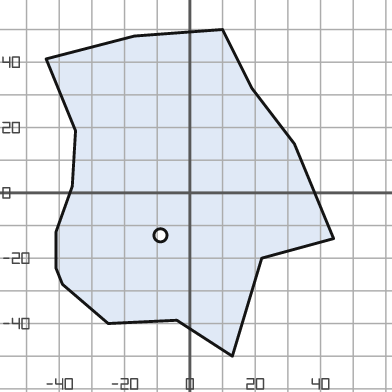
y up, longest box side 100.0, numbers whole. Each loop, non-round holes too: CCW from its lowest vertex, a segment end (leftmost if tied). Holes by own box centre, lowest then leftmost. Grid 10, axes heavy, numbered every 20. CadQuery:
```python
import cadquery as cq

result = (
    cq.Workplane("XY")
    .moveTo(13.0, -50.0)
    .lineTo(22.0, -20.0)
    .lineTo(44.0, -14.0)
    .lineTo(32.0, 15.0)
    .lineTo(19.0, 32.0)
    .lineTo(10.0, 50.0)
    .lineTo(-17.0, 48.0)
    .lineTo(-44.0, 41.0)
    .lineTo(-35.0, 19.0)
    .lineTo(-36.0, 2.0)
    .lineTo(-41.0, -12.0)
    .lineTo(-41.0, -23.0)
    .lineTo(-39.0, -28.0)
    .lineTo(-25.0, -40.0)
    .lineTo(-4.0, -39.0)
    .close()
    .moveTo(-9.0, -13.0)
    .circle(2.0)
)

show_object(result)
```